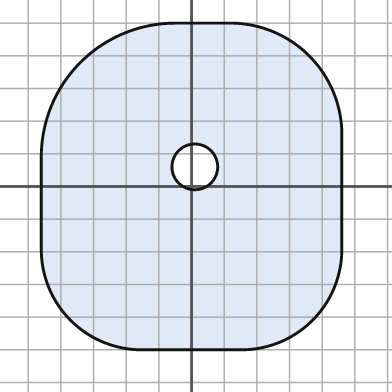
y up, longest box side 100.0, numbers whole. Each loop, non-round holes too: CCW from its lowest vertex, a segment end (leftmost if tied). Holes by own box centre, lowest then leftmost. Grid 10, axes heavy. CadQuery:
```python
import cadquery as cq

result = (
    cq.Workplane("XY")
    .moveTo(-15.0, -50.0)
    .lineTo(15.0, -50.0)
    .threePointArc((37.0, -41.0), (46.0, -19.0))
    .lineTo(46.0, 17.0)
    .threePointArc((36.0, 40.0), (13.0, 50.0))
    .lineTo(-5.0, 50.0)
    .threePointArc((-34.0, 38.0), (-46.0, 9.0))
    .lineTo(-46.0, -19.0)
    .threePointArc((-37.0, -41.0), (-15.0, -50.0))
    .close()
    .moveTo(1.0, 6.0)
    .circle(7.0)
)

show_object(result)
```